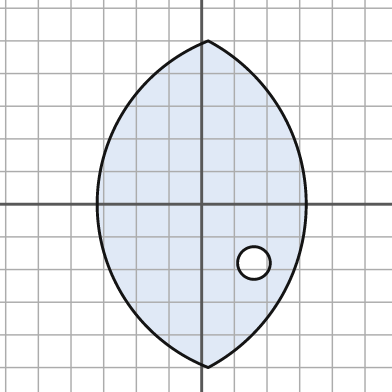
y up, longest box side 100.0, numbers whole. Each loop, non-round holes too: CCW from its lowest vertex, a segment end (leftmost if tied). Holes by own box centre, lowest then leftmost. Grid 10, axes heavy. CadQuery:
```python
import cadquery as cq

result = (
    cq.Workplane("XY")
    .moveTo(2.0, -50.0)
    .threePointArc((32.0, 0.0), (2.0, 50.0))
    .threePointArc((-32.0, 0.0), (2.0, -50.0))
    .close()
    .moveTo(16.0, -18.0)
    .circle(5.0)
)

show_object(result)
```